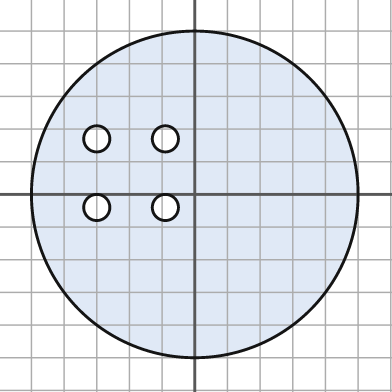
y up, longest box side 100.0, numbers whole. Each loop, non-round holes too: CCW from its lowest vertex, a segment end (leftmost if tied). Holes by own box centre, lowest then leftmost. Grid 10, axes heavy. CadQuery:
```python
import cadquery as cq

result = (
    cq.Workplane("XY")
    .moveTo(0.0, 0.0)
    .circle(50.0)
    .moveTo(-30.0, -4.0)
    .circle(4.0)
    .moveTo(-9.0, -4.0)
    .circle(4.0)
    .moveTo(-30.0, 17.0)
    .circle(4.0)
    .moveTo(-9.0, 17.0)
    .circle(4.0)
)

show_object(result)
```